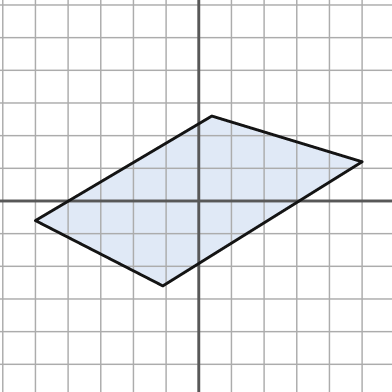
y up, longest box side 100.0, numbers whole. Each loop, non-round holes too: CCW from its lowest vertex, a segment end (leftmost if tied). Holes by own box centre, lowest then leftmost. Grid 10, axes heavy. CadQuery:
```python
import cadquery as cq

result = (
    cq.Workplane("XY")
    .moveTo(-11.0, -26.0)
    .lineTo(50.0, 12.0)
    .lineTo(4.0, 26.0)
    .lineTo(-50.0, -6.0)
    .close()
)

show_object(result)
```